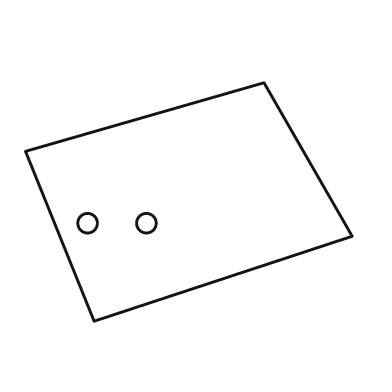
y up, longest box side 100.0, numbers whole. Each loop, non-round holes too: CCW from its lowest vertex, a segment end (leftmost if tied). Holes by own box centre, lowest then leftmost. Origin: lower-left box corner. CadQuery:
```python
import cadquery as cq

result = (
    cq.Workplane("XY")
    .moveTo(21.0, 0.0)
    .lineTo(100.0, 26.0)
    .lineTo(73.0, 73.0)
    .lineTo(0.0, 52.0)
    .close()
    .moveTo(19.0, 30.0)
    .circle(3.0)
    .moveTo(37.0, 30.0)
    .circle(3.0)
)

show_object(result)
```